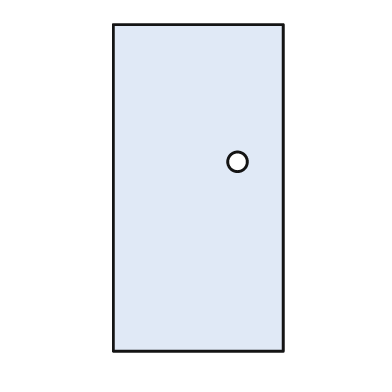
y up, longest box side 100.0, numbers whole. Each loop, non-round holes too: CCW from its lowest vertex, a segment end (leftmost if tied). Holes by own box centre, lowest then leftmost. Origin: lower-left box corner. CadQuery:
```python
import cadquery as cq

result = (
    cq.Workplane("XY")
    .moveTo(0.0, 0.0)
    .lineTo(52.0, 0.0)
    .lineTo(52.0, 100.0)
    .lineTo(0.0, 100.0)
    .close()
    .moveTo(38.0, 58.0)
    .circle(3.0)
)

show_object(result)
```